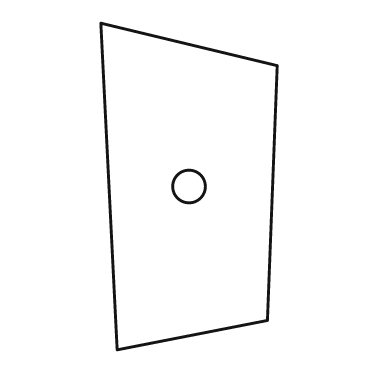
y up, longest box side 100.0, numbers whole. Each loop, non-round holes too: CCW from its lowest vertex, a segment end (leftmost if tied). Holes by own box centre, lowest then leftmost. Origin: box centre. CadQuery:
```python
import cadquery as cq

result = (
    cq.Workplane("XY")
    .moveTo(-22.0, -50.0)
    .lineTo(24.0, -41.0)
    .lineTo(27.0, 37.0)
    .lineTo(-27.0, 50.0)
    .close()
    .moveTo(0.0, 0.0)
    .circle(5.0)
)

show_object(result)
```